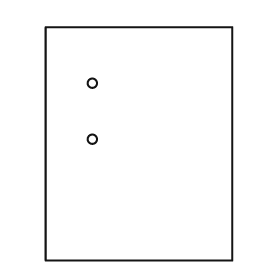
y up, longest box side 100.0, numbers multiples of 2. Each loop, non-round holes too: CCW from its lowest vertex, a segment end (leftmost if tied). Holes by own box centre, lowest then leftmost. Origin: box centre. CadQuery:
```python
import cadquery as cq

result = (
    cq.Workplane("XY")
    .moveTo(-40.0, -50.0)
    .lineTo(40.0, -50.0)
    .lineTo(40.0, 50.0)
    .lineTo(-40.0, 50.0)
    .close()
    .moveTo(-20.0, 2.0)
    .circle(2.0)
    .moveTo(-20.0, 26.0)
    .circle(2.0)
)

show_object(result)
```